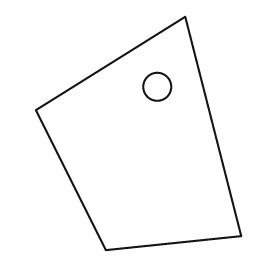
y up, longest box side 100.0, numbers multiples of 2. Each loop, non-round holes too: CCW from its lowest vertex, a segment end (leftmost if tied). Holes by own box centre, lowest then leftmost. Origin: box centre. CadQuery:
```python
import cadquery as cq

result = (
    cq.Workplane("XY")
    .moveTo(-14.0, -50.0)
    .lineTo(44.0, -44.0)
    .lineTo(20.0, 50.0)
    .lineTo(-44.0, 10.0)
    .close()
    .moveTo(8.0, 20.0)
    .circle(6.0)
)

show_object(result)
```